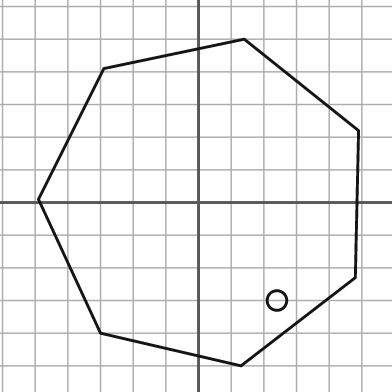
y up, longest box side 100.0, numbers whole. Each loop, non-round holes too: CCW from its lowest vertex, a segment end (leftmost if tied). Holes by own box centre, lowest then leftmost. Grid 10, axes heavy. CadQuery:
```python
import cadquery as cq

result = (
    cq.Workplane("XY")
    .moveTo(13.0, -50.0)
    .lineTo(48.0, -23.0)
    .lineTo(49.0, 22.0)
    .lineTo(14.0, 50.0)
    .lineTo(-29.0, 41.0)
    .lineTo(-49.0, 1.0)
    .lineTo(-30.0, -40.0)
    .close()
    .moveTo(24.0, -30.0)
    .circle(3.0)
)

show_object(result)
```